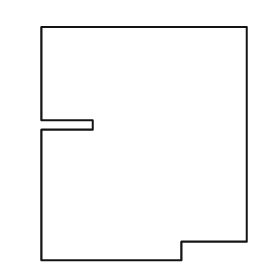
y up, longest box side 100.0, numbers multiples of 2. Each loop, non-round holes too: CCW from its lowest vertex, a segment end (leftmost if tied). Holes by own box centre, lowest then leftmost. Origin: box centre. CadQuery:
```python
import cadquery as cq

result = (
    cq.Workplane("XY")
    .moveTo(-44.0, -50.0)
    .lineTo(16.0, -50.0)
    .lineTo(16.0, -42.0)
    .lineTo(44.0, -42.0)
    .lineTo(44.0, 50.0)
    .lineTo(-44.0, 50.0)
    .lineTo(-44.0, 10.0)
    .lineTo(-22.0, 10.0)
    .lineTo(-22.0, 6.0)
    .lineTo(-44.0, 6.0)
    .close()
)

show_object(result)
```